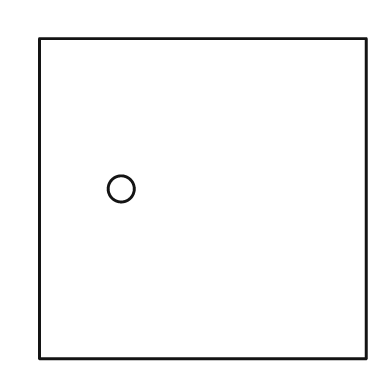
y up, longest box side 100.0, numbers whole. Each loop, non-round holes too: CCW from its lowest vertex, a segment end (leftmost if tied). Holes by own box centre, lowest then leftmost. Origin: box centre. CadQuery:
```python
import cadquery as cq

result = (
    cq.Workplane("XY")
    .moveTo(-50.0, -49.0)
    .lineTo(50.0, -49.0)
    .lineTo(50.0, 49.0)
    .lineTo(-50.0, 49.0)
    .close()
    .moveTo(-25.0, 3.0)
    .circle(4.0)
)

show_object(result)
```